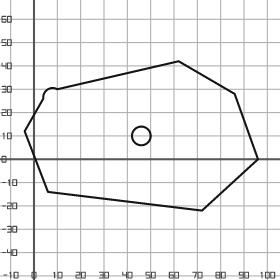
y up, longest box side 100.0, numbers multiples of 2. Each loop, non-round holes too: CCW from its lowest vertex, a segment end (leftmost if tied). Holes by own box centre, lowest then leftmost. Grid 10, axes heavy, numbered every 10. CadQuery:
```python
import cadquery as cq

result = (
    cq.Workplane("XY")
    .moveTo(72.0, -22.0)
    .lineTo(96.0, 0.0)
    .lineTo(86.0, 28.0)
    .lineTo(62.0, 42.0)
    .lineTo(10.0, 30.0)
    .threePointArc((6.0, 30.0), (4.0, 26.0))
    .lineTo(-4.0, 12.0)
    .lineTo(6.0, -14.0)
    .close()
    .moveTo(46.0, 10.0)
    .circle(4.0)
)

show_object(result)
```